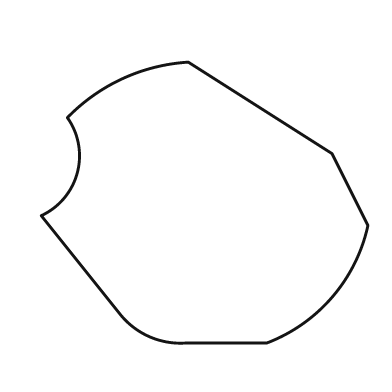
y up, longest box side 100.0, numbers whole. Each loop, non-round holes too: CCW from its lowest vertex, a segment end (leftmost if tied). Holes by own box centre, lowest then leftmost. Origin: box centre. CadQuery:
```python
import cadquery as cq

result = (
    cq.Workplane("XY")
    .moveTo(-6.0, -43.0)
    .lineTo(19.0, -43.0)
    .threePointArc((39.0, -29.0), (50.0, -7.0))
    .lineTo(39.0, 15.0)
    .lineTo(-5.0, 43.0)
    .threePointArc((-25.0, 38.0), (-42.0, 26.0))
    .threePointArc((-39.0, 9.0), (-50.0, -4.0))
    .lineTo(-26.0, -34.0)
    .threePointArc((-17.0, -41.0), (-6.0, -43.0))
    .close()
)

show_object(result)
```